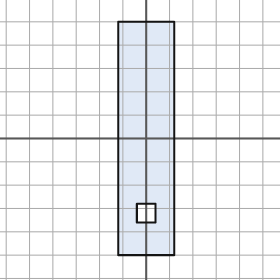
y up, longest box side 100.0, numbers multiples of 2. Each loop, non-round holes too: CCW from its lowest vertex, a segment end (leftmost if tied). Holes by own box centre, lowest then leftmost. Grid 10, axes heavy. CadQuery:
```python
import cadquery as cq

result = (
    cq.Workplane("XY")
    .moveTo(-12.0, -50.0)
    .lineTo(12.0, -50.0)
    .lineTo(12.0, 50.0)
    .lineTo(-12.0, 50.0)
    .close()
    .moveTo(-4.0, -36.0)
    .lineTo(4.0, -36.0)
    .lineTo(4.0, -28.0)
    .lineTo(-4.0, -28.0)
    .close()
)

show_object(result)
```